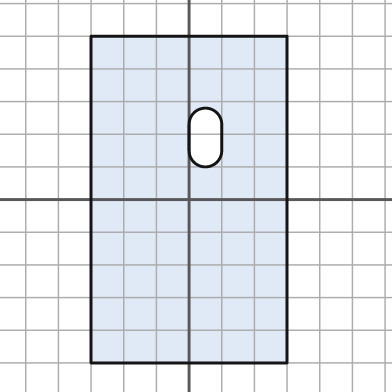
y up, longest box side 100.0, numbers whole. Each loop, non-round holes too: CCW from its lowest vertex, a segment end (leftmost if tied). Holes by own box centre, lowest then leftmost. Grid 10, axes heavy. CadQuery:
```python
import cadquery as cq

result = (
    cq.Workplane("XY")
    .moveTo(-30.0, -50.0)
    .lineTo(30.0, -50.0)
    .lineTo(30.0, 50.0)
    .lineTo(-30.0, 50.0)
    .close()
    .moveTo(0.0, 15.0)
    .threePointArc((5.0, 10.0), (10.0, 15.0))
    .lineTo(10.0, 23.0)
    .threePointArc((5.0, 28.0), (0.0, 23.0))
    .close()
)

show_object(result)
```